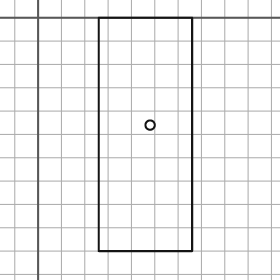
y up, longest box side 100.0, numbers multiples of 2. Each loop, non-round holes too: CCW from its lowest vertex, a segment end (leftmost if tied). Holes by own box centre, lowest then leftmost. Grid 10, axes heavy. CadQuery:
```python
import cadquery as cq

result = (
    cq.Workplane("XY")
    .moveTo(26.0, -100.0)
    .lineTo(66.0, -100.0)
    .lineTo(66.0, 0.0)
    .lineTo(26.0, 0.0)
    .close()
    .moveTo(48.0, -46.0)
    .circle(2.0)
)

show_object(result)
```